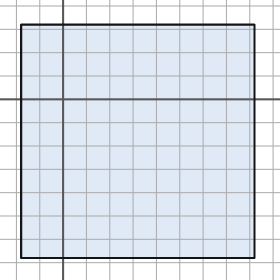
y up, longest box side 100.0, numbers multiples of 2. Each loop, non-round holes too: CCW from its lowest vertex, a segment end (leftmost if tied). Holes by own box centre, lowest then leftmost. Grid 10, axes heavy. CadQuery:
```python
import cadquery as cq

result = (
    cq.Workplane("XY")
    .moveTo(-18.0, -68.0)
    .lineTo(82.0, -68.0)
    .lineTo(82.0, 32.0)
    .lineTo(-18.0, 32.0)
    .close()
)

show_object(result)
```